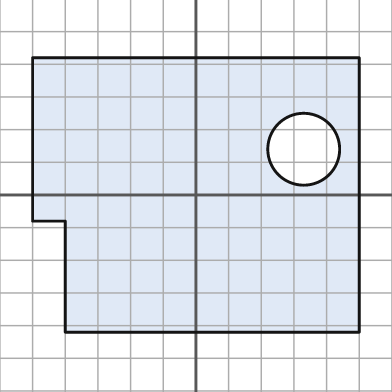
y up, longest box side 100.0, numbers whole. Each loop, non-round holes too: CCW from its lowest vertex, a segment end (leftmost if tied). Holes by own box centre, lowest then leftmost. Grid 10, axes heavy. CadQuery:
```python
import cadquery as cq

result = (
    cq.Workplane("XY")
    .moveTo(-40.0, -42.0)
    .lineTo(50.0, -42.0)
    .lineTo(50.0, 42.0)
    .lineTo(-50.0, 42.0)
    .lineTo(-50.0, -8.0)
    .lineTo(-40.0, -8.0)
    .close()
    .moveTo(33.0, 14.0)
    .circle(11.0)
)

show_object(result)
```